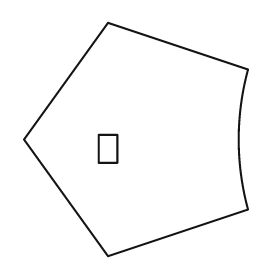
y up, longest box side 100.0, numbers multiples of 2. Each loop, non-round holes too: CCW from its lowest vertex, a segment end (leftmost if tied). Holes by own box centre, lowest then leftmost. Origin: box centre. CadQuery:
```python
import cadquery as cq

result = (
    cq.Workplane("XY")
    .moveTo(-12.0, -50.0)
    .lineTo(48.0, -30.0)
    .threePointArc((44.0, 0.0), (48.0, 30.0))
    .lineTo(-12.0, 50.0)
    .lineTo(-48.0, 0.0)
    .close()
    .moveTo(-16.0, -10.0)
    .lineTo(-8.0, -10.0)
    .lineTo(-8.0, 2.0)
    .lineTo(-16.0, 2.0)
    .close()
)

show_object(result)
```